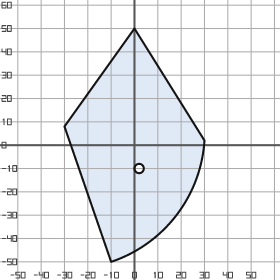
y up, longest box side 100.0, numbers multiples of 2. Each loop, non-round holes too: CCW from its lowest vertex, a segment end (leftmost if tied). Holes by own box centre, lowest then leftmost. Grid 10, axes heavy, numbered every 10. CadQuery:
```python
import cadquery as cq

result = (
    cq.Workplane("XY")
    .moveTo(-10.0, -50.0)
    .threePointArc((18.0, -30.0), (30.0, 2.0))
    .lineTo(0.0, 50.0)
    .lineTo(-30.0, 8.0)
    .close()
    .moveTo(2.0, -10.0)
    .circle(2.0)
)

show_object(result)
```